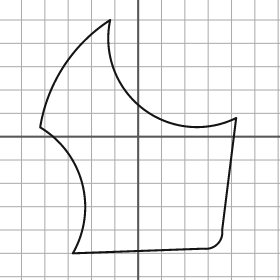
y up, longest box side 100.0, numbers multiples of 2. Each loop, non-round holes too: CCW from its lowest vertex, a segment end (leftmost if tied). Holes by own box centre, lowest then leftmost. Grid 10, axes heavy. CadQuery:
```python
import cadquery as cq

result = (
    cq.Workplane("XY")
    .moveTo(-28.0, -50.0)
    .lineTo(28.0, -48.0)
    .threePointArc((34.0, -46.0), (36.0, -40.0))
    .lineTo(42.0, 8.0)
    .threePointArc((2.0, 12.0), (-12.0, 50.0))
    .threePointArc((-32.0, 30.0), (-42.0, 4.0))
    .threePointArc((-24.0, -20.0), (-28.0, -50.0))
    .close()
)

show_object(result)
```